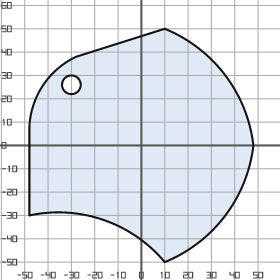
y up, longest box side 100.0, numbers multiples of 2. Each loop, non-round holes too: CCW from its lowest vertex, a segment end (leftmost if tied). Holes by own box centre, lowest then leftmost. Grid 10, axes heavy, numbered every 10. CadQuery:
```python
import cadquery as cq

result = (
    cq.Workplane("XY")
    .moveTo(10.0, -50.0)
    .threePointArc((36.0, -30.0), (48.0, 0.0))
    .threePointArc((36.0, 30.0), (10.0, 50.0))
    .lineTo(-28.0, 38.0)
    .threePointArc((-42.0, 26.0), (-48.0, 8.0))
    .lineTo(-48.0, -30.0)
    .threePointArc((-16.0, -32.0), (10.0, -50.0))
    .close()
    .moveTo(-30.0, 26.0)
    .circle(4.0)
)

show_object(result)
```